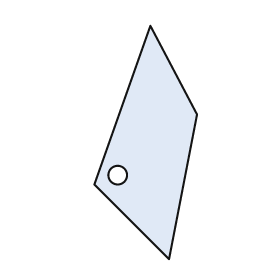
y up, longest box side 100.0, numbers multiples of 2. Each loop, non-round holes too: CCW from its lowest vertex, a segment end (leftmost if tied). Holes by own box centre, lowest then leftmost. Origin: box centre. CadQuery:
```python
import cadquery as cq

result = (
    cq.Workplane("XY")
    .moveTo(10.0, -50.0)
    .lineTo(22.0, 12.0)
    .lineTo(2.0, 50.0)
    .lineTo(-22.0, -18.0)
    .close()
    .moveTo(-12.0, -14.0)
    .circle(4.0)
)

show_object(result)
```